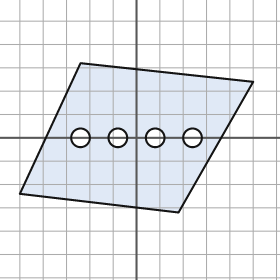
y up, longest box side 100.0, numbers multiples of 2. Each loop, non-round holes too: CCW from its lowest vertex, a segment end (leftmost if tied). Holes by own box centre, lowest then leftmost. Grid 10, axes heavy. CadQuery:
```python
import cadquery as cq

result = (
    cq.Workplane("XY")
    .moveTo(18.0, -32.0)
    .lineTo(50.0, 24.0)
    .lineTo(-24.0, 32.0)
    .lineTo(-50.0, -24.0)
    .close()
    .moveTo(-24.0, 0.0)
    .circle(4.0)
    .moveTo(-8.0, 0.0)
    .circle(4.0)
    .moveTo(8.0, 0.0)
    .circle(4.0)
    .moveTo(24.0, 0.0)
    .circle(4.0)
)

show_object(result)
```